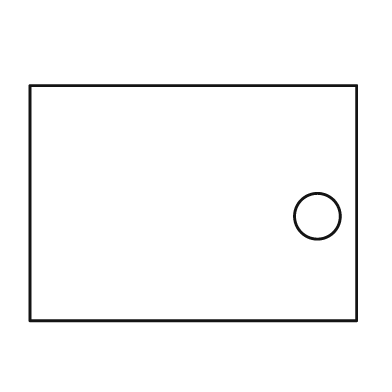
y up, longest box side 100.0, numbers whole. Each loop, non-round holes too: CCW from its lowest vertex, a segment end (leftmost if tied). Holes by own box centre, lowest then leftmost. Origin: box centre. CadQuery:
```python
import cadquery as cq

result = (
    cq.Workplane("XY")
    .moveTo(-50.0, -36.0)
    .lineTo(50.0, -36.0)
    .lineTo(50.0, 36.0)
    .lineTo(-50.0, 36.0)
    .close()
    .moveTo(38.0, -4.0)
    .circle(7.0)
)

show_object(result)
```